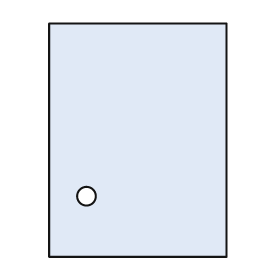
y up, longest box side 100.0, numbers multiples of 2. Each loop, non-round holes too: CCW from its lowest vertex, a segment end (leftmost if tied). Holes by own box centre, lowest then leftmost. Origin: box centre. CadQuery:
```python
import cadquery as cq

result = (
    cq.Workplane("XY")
    .moveTo(-38.0, -50.0)
    .lineTo(38.0, -50.0)
    .lineTo(38.0, 50.0)
    .lineTo(-38.0, 50.0)
    .close()
    .moveTo(-22.0, -24.0)
    .circle(4.0)
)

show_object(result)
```